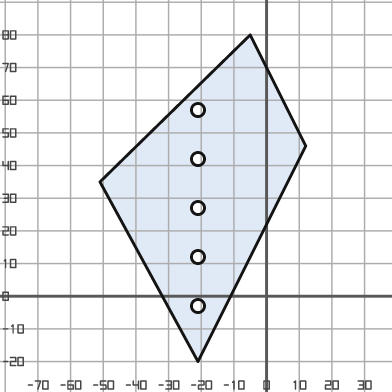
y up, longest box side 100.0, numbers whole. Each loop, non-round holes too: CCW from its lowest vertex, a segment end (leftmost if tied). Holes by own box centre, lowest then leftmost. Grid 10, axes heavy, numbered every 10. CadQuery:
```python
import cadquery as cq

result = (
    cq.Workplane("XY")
    .moveTo(-21.0, -20.0)
    .lineTo(12.0, 46.0)
    .lineTo(-5.0, 80.0)
    .lineTo(-51.0, 35.0)
    .close()
    .moveTo(-21.0, -3.0)
    .circle(2.0)
    .moveTo(-21.0, 12.0)
    .circle(2.0)
    .moveTo(-21.0, 27.0)
    .circle(2.0)
    .moveTo(-21.0, 42.0)
    .circle(2.0)
    .moveTo(-21.0, 57.0)
    .circle(2.0)
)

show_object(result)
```